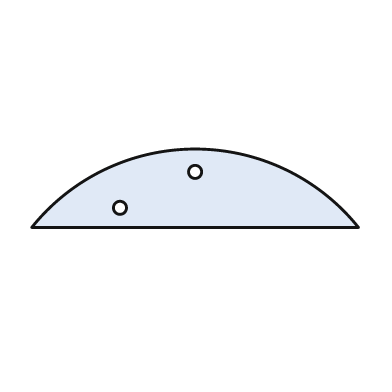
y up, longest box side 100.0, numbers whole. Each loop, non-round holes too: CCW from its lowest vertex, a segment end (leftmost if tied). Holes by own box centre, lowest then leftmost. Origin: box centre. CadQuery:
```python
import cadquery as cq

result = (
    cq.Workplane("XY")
    .moveTo(-50.0, -12.0)
    .lineTo(50.0, -12.0)
    .threePointArc((0.0, 12.0), (-50.0, -12.0))
    .close()
    .moveTo(-23.0, -6.0)
    .circle(2.0)
    .moveTo(0.0, 5.0)
    .circle(2.0)
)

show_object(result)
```